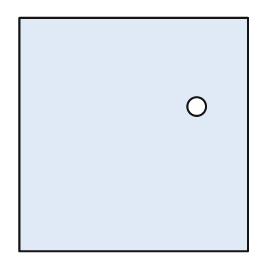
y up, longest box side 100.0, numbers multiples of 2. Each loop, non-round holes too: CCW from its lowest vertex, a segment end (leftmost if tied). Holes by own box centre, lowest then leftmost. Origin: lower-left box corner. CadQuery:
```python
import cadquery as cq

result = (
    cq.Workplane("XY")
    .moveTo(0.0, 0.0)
    .lineTo(98.0, 0.0)
    .lineTo(98.0, 100.0)
    .lineTo(0.0, 100.0)
    .close()
    .moveTo(76.0, 62.0)
    .circle(4.0)
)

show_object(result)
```